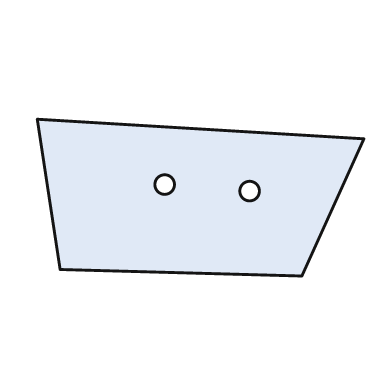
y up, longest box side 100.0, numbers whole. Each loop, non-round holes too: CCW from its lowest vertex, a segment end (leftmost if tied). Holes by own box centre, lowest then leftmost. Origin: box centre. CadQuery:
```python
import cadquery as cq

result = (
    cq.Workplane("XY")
    .moveTo(31.0, -24.0)
    .lineTo(50.0, 18.0)
    .lineTo(-50.0, 24.0)
    .lineTo(-43.0, -22.0)
    .close()
    .moveTo(15.0, 2.0)
    .circle(3.0)
    .moveTo(-11.0, 4.0)
    .circle(3.0)
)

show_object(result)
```